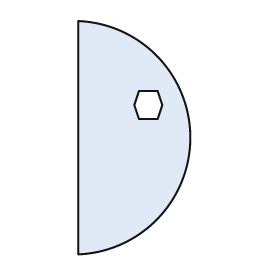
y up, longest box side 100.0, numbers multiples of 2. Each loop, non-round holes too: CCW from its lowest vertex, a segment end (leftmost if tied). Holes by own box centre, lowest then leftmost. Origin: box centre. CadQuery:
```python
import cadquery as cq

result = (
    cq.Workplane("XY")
    .moveTo(-24.0, -50.0)
    .threePointArc((24.0, 0.0), (-24.0, 50.0))
    .close()
    .moveTo(2.0, 8.0)
    .lineTo(10.0, 8.0)
    .lineTo(12.0, 14.0)
    .lineTo(10.0, 20.0)
    .lineTo(2.0, 20.0)
    .lineTo(0.0, 14.0)
    .close()
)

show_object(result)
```